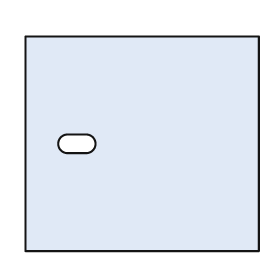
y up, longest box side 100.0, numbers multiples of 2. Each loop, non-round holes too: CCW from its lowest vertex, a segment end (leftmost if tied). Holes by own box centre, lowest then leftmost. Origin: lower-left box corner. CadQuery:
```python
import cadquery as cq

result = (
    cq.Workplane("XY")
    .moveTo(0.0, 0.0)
    .lineTo(100.0, 0.0)
    .lineTo(100.0, 92.0)
    .lineTo(0.0, 92.0)
    .close()
    .moveTo(18.0, 42.0)
    .lineTo(26.0, 42.0)
    .threePointArc((30.0, 46.0), (26.0, 50.0))
    .lineTo(18.0, 50.0)
    .threePointArc((14.0, 46.0), (18.0, 42.0))
    .close()
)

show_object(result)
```